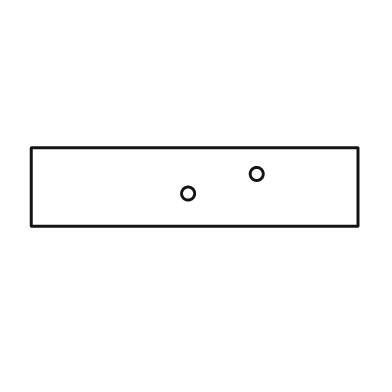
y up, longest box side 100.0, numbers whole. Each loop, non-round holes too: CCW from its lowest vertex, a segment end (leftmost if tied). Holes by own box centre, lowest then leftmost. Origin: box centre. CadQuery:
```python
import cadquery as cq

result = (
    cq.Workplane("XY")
    .moveTo(-50.0, -12.0)
    .lineTo(50.0, -12.0)
    .lineTo(50.0, 12.0)
    .lineTo(-50.0, 12.0)
    .close()
    .moveTo(-2.0, -2.0)
    .circle(2.0)
    .moveTo(19.0, 4.0)
    .circle(2.0)
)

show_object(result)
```